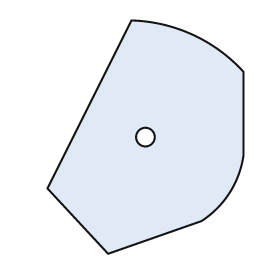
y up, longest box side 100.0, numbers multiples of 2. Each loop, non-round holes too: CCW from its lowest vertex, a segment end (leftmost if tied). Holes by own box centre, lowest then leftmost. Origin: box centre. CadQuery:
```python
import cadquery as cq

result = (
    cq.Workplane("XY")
    .moveTo(-16.0, -50.0)
    .lineTo(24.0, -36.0)
    .threePointArc((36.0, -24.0), (42.0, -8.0))
    .lineTo(42.0, 28.0)
    .threePointArc((20.0, 44.0), (-6.0, 50.0))
    .lineTo(-42.0, -22.0)
    .close()
    .moveTo(0.0, 0.0)
    .circle(4.0)
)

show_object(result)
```